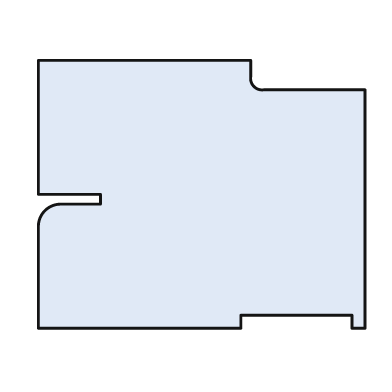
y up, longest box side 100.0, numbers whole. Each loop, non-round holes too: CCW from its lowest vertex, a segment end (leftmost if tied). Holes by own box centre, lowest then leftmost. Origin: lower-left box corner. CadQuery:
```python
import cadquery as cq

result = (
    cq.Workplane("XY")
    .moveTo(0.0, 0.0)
    .lineTo(62.0, 0.0)
    .lineTo(62.0, 4.0)
    .lineTo(96.0, 4.0)
    .lineTo(96.0, 0.0)
    .lineTo(100.0, 0.0)
    .lineTo(100.0, 73.0)
    .lineTo(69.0, 73.0)
    .threePointArc((66.0, 74.0), (65.0, 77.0))
    .lineTo(65.0, 82.0)
    .lineTo(0.0, 82.0)
    .lineTo(0.0, 41.0)
    .lineTo(19.0, 41.0)
    .lineTo(19.0, 38.0)
    .lineTo(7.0, 38.0)
    .threePointArc((2.0, 36.0), (0.0, 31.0))
    .close()
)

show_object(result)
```